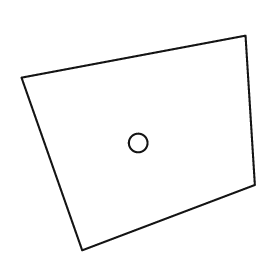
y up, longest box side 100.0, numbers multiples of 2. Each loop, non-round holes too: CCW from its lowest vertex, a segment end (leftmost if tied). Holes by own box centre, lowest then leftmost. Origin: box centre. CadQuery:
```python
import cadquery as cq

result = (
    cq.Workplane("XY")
    .moveTo(-24.0, -46.0)
    .lineTo(50.0, -18.0)
    .lineTo(46.0, 46.0)
    .lineTo(-50.0, 28.0)
    .close()
    .moveTo(0.0, 0.0)
    .circle(4.0)
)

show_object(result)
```